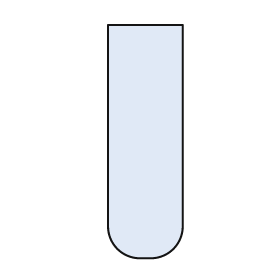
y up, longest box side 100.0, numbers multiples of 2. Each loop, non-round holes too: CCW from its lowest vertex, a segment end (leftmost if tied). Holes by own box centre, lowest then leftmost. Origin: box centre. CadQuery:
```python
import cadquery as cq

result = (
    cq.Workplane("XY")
    .moveTo(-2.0, -50.0)
    .lineTo(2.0, -50.0)
    .threePointArc((12.0, -46.0), (16.0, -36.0))
    .lineTo(16.0, 50.0)
    .lineTo(-16.0, 50.0)
    .lineTo(-16.0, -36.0)
    .threePointArc((-12.0, -46.0), (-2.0, -50.0))
    .close()
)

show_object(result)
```